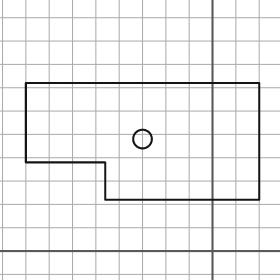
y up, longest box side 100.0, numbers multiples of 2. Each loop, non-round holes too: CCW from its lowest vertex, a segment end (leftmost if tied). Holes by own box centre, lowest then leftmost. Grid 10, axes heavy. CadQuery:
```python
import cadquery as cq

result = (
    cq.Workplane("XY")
    .moveTo(-46.0, 22.0)
    .lineTo(20.0, 22.0)
    .lineTo(20.0, 72.0)
    .lineTo(-80.0, 72.0)
    .lineTo(-80.0, 38.0)
    .lineTo(-46.0, 38.0)
    .close()
    .moveTo(-30.0, 48.0)
    .circle(4.0)
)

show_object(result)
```